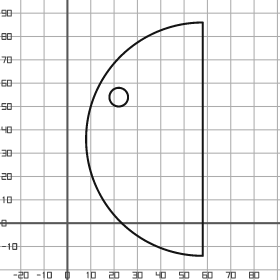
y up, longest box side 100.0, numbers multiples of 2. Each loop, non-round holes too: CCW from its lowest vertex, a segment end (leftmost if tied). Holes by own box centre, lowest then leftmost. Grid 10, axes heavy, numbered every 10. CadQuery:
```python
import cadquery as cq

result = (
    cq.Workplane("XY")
    .moveTo(58.0, -14.0)
    .lineTo(58.0, 86.0)
    .threePointArc((8.0, 36.0), (58.0, -14.0))
    .close()
    .moveTo(22.0, 54.0)
    .circle(4.0)
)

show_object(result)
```